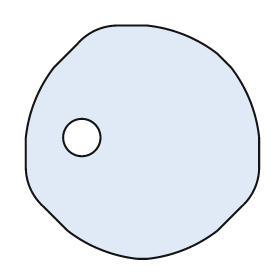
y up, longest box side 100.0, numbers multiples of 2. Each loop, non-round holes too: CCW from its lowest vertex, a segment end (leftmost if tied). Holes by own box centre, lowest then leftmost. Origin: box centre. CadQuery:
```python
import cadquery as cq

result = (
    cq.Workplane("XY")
    .moveTo(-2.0, -50.0)
    .lineTo(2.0, -50.0)
    .threePointArc((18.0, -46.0), (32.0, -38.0))
    .lineTo(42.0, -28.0)
    .threePointArc((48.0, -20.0), (50.0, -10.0))
    .lineTo(50.0, 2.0)
    .threePointArc((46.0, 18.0), (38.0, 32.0))
    .lineTo(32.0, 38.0)
    .threePointArc((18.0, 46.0), (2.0, 50.0))
    .lineTo(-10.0, 50.0)
    .threePointArc((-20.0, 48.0), (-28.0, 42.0))
    .lineTo(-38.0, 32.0)
    .threePointArc((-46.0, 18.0), (-50.0, 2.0))
    .lineTo(-50.0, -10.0)
    .threePointArc((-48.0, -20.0), (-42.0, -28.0))
    .lineTo(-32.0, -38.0)
    .threePointArc((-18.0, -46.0), (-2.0, -50.0))
    .close()
    .moveTo(-26.0, 2.0)
    .circle(8.0)
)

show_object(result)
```